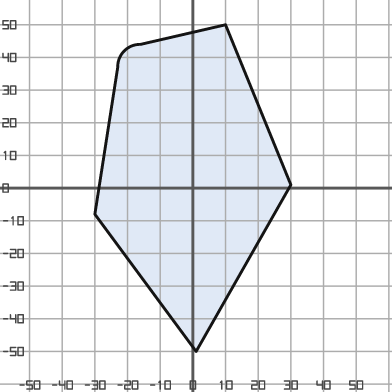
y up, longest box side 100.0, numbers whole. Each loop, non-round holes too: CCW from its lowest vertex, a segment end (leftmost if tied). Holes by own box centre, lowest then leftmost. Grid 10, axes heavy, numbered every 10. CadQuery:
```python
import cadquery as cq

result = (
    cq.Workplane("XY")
    .moveTo(1.0, -50.0)
    .lineTo(30.0, 1.0)
    .lineTo(10.0, 50.0)
    .lineTo(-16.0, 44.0)
    .threePointArc((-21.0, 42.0), (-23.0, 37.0))
    .lineTo(-30.0, -8.0)
    .close()
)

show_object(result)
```